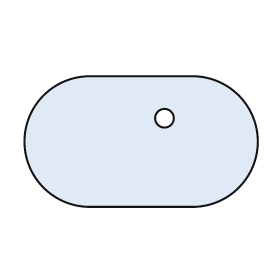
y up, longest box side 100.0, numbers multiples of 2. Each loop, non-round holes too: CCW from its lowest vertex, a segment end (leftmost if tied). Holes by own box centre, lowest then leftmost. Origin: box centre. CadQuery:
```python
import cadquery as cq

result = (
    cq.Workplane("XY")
    .moveTo(-22.0, -28.0)
    .lineTo(22.0, -28.0)
    .threePointArc((50.0, 0.0), (22.0, 28.0))
    .lineTo(-22.0, 28.0)
    .threePointArc((-50.0, 0.0), (-22.0, -28.0))
    .close()
    .moveTo(10.0, 10.0)
    .circle(4.0)
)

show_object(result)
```